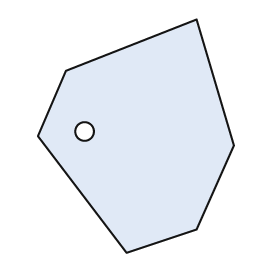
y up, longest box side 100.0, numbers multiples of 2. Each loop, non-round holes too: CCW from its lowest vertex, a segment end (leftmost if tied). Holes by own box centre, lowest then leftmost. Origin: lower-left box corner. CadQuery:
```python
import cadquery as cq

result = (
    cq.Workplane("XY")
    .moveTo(38.0, 0.0)
    .lineTo(68.0, 10.0)
    .lineTo(84.0, 46.0)
    .lineTo(68.0, 100.0)
    .lineTo(12.0, 78.0)
    .lineTo(0.0, 50.0)
    .close()
    .moveTo(20.0, 52.0)
    .circle(4.0)
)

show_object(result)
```